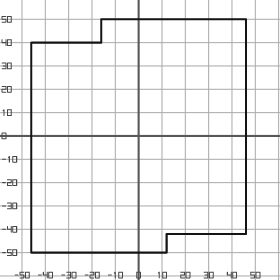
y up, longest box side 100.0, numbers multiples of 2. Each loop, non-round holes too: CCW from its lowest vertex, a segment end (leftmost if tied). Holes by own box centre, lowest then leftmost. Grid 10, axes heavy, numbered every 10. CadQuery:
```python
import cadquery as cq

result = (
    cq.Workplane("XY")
    .moveTo(-46.0, -50.0)
    .lineTo(12.0, -50.0)
    .lineTo(12.0, -42.0)
    .lineTo(46.0, -42.0)
    .lineTo(46.0, 50.0)
    .lineTo(-16.0, 50.0)
    .lineTo(-16.0, 40.0)
    .lineTo(-46.0, 40.0)
    .close()
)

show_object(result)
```